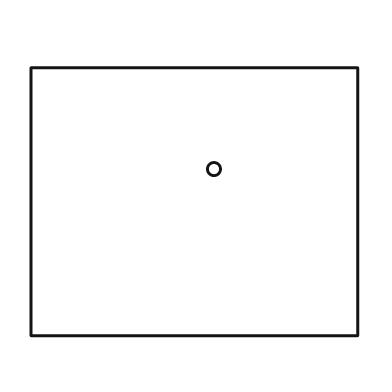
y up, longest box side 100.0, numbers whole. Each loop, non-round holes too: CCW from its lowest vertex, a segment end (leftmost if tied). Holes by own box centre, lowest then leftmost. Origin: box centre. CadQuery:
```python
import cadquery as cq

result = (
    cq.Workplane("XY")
    .moveTo(-50.0, -41.0)
    .lineTo(50.0, -41.0)
    .lineTo(50.0, 41.0)
    .lineTo(-50.0, 41.0)
    .close()
    .moveTo(6.0, 10.0)
    .circle(2.0)
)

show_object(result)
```